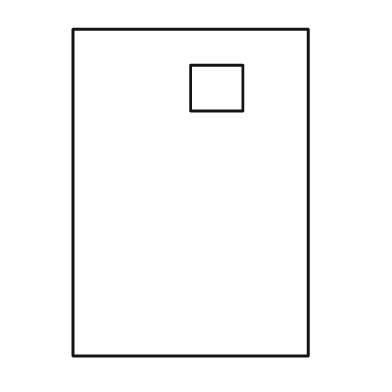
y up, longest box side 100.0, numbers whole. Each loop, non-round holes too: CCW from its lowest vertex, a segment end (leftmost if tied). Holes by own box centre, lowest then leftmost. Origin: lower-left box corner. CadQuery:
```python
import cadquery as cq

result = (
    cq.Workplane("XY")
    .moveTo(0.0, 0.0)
    .lineTo(72.0, 0.0)
    .lineTo(72.0, 100.0)
    .lineTo(0.0, 100.0)
    .close()
    .moveTo(36.0, 75.0)
    .lineTo(52.0, 75.0)
    .lineTo(52.0, 89.0)
    .lineTo(36.0, 89.0)
    .close()
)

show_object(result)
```